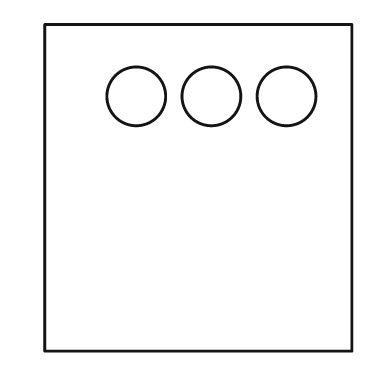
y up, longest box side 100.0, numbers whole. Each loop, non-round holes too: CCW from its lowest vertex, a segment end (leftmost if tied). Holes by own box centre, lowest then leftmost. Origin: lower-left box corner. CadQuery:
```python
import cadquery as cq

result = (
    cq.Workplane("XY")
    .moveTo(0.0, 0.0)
    .lineTo(94.0, 0.0)
    .lineTo(94.0, 100.0)
    .lineTo(0.0, 100.0)
    .close()
    .moveTo(28.0, 78.0)
    .circle(9.0)
    .moveTo(51.0, 78.0)
    .circle(9.0)
    .moveTo(74.0, 78.0)
    .circle(9.0)
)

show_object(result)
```